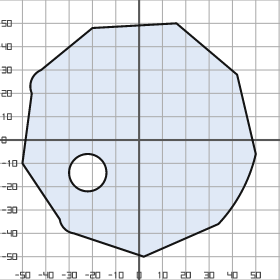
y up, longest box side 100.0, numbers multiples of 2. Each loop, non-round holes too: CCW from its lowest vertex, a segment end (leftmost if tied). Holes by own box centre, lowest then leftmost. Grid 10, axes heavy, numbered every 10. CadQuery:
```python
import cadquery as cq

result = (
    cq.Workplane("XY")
    .moveTo(2.0, -50.0)
    .lineTo(34.0, -36.0)
    .threePointArc((44.0, -22.0), (50.0, -6.0))
    .lineTo(42.0, 28.0)
    .lineTo(16.0, 50.0)
    .lineTo(-20.0, 48.0)
    .lineTo(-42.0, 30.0)
    .threePointArc((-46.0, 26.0), (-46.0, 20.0))
    .lineTo(-50.0, -10.0)
    .lineTo(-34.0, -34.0)
    .threePointArc((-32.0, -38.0), (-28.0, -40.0))
    .close()
    .moveTo(-22.0, -14.0)
    .circle(8.0)
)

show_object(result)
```